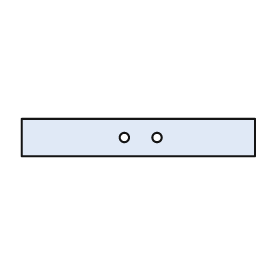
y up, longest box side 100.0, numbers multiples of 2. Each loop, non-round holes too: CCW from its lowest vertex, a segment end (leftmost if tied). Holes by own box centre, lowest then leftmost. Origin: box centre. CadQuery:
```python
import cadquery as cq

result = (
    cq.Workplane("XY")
    .moveTo(-50.0, -8.0)
    .lineTo(50.0, -8.0)
    .lineTo(50.0, 8.0)
    .lineTo(-50.0, 8.0)
    .close()
    .moveTo(-6.0, 0.0)
    .circle(2.0)
    .moveTo(8.0, 0.0)
    .circle(2.0)
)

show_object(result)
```